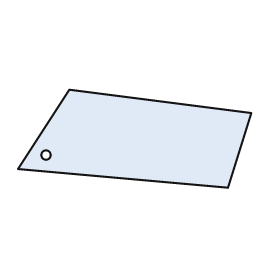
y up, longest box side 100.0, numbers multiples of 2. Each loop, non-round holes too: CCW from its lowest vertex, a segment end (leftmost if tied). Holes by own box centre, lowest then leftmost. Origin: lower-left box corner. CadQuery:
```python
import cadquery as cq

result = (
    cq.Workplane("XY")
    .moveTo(90.0, 0.0)
    .lineTo(100.0, 32.0)
    .lineTo(22.0, 42.0)
    .lineTo(0.0, 8.0)
    .close()
    .moveTo(12.0, 14.0)
    .circle(2.0)
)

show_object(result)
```